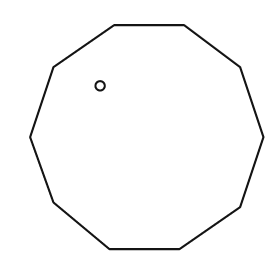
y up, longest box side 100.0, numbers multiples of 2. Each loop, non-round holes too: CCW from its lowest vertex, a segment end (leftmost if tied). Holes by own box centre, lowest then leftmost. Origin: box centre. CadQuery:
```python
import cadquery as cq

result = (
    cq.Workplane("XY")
    .moveTo(-16.0, -48.0)
    .lineTo(14.0, -48.0)
    .lineTo(40.0, -30.0)
    .lineTo(50.0, 0.0)
    .lineTo(40.0, 30.0)
    .lineTo(16.0, 48.0)
    .lineTo(-14.0, 48.0)
    .lineTo(-40.0, 30.0)
    .lineTo(-50.0, 0.0)
    .lineTo(-40.0, -28.0)
    .close()
    .moveTo(-20.0, 22.0)
    .circle(2.0)
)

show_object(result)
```